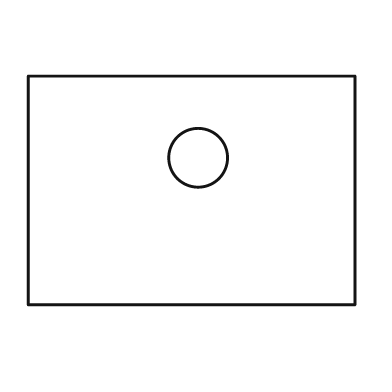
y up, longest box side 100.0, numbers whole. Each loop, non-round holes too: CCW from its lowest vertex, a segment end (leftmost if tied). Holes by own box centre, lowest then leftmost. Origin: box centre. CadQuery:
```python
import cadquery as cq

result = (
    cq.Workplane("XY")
    .moveTo(-50.0, -35.0)
    .lineTo(50.0, -35.0)
    .lineTo(50.0, 35.0)
    .lineTo(-50.0, 35.0)
    .close()
    .moveTo(2.0, 10.0)
    .circle(9.0)
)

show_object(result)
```